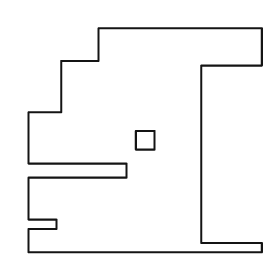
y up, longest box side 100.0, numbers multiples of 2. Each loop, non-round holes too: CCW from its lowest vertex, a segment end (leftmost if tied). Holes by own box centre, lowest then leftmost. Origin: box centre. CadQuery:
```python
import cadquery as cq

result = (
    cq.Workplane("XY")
    .moveTo(-50.0, -48.0)
    .lineTo(50.0, -48.0)
    .lineTo(50.0, -44.0)
    .lineTo(24.0, -44.0)
    .lineTo(24.0, 32.0)
    .lineTo(50.0, 32.0)
    .lineTo(50.0, 48.0)
    .lineTo(-20.0, 48.0)
    .lineTo(-20.0, 34.0)
    .lineTo(-36.0, 34.0)
    .lineTo(-36.0, 12.0)
    .lineTo(-50.0, 12.0)
    .lineTo(-50.0, -10.0)
    .lineTo(-8.0, -10.0)
    .lineTo(-8.0, -16.0)
    .lineTo(-50.0, -16.0)
    .lineTo(-50.0, -34.0)
    .lineTo(-38.0, -34.0)
    .lineTo(-38.0, -38.0)
    .lineTo(-50.0, -38.0)
    .close()
    .moveTo(-4.0, -4.0)
    .lineTo(4.0, -4.0)
    .lineTo(4.0, 4.0)
    .lineTo(-4.0, 4.0)
    .close()
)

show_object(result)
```